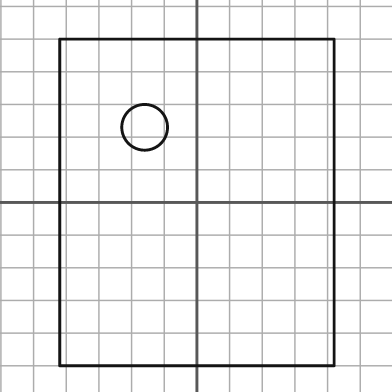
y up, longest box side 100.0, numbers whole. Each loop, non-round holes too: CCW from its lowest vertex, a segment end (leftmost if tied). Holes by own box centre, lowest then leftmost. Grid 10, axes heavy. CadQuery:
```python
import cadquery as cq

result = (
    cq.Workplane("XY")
    .moveTo(-42.0, -50.0)
    .lineTo(42.0, -50.0)
    .lineTo(42.0, 50.0)
    .lineTo(-42.0, 50.0)
    .close()
    .moveTo(-16.0, 23.0)
    .circle(7.0)
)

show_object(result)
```